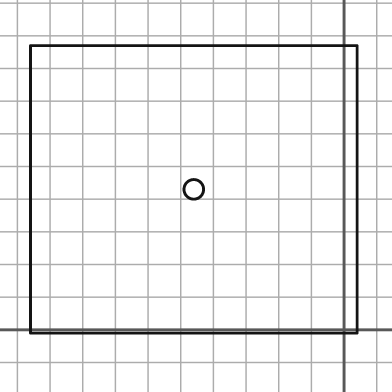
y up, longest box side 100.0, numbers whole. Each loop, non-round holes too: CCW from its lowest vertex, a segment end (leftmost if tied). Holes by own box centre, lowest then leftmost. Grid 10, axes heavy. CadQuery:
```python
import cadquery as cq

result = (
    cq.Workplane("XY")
    .moveTo(-96.0, -1.0)
    .lineTo(4.0, -1.0)
    .lineTo(4.0, 87.0)
    .lineTo(-96.0, 87.0)
    .close()
    .moveTo(-46.0, 43.0)
    .circle(3.0)
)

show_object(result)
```